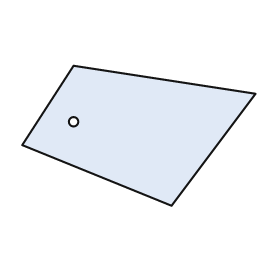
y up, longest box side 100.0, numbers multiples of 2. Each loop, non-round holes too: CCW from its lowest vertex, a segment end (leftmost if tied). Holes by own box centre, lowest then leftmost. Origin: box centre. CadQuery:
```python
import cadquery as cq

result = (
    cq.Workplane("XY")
    .moveTo(14.0, -30.0)
    .lineTo(50.0, 18.0)
    .lineTo(-28.0, 30.0)
    .lineTo(-50.0, -4.0)
    .close()
    .moveTo(-28.0, 6.0)
    .circle(2.0)
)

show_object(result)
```